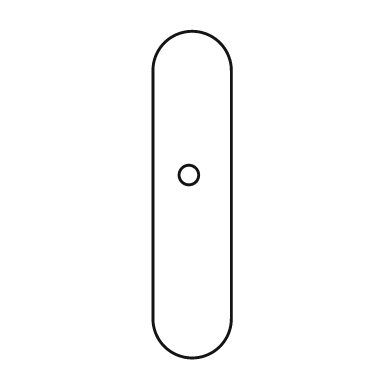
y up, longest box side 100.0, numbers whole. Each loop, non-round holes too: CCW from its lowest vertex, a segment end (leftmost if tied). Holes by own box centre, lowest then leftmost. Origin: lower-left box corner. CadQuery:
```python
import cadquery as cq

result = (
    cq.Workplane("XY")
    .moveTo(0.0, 12.0)
    .threePointArc((12.0, 0.0), (24.0, 12.0))
    .lineTo(24.0, 88.0)
    .threePointArc((12.0, 100.0), (0.0, 88.0))
    .close()
    .moveTo(11.0, 56.0)
    .circle(3.0)
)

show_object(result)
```